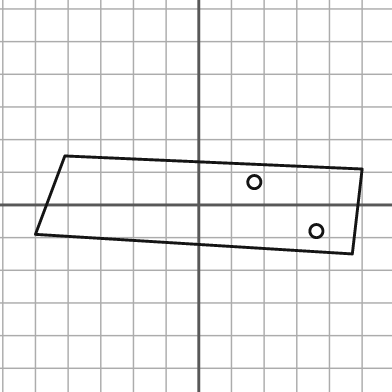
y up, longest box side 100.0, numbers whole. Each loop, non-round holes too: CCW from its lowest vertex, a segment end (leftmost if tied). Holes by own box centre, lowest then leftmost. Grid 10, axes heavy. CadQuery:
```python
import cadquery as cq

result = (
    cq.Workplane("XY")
    .moveTo(47.0, -15.0)
    .lineTo(50.0, 11.0)
    .lineTo(-41.0, 15.0)
    .lineTo(-50.0, -9.0)
    .close()
    .moveTo(36.0, -8.0)
    .circle(2.0)
    .moveTo(17.0, 7.0)
    .circle(2.0)
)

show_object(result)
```